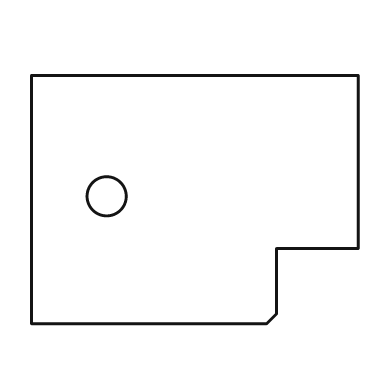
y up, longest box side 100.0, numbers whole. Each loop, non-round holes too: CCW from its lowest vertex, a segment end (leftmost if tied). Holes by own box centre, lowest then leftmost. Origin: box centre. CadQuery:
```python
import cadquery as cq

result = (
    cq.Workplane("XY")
    .moveTo(-50.0, -38.0)
    .lineTo(22.0, -38.0)
    .lineTo(25.0, -35.0)
    .lineTo(25.0, -15.0)
    .lineTo(50.0, -15.0)
    .lineTo(50.0, 38.0)
    .lineTo(-50.0, 38.0)
    .close()
    .moveTo(-27.0, 1.0)
    .circle(6.0)
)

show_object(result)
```